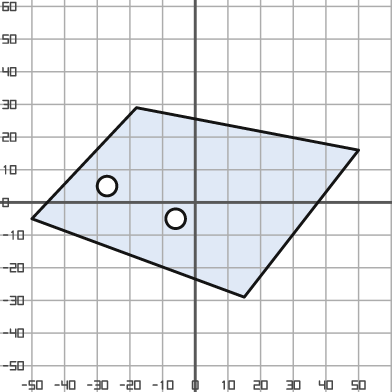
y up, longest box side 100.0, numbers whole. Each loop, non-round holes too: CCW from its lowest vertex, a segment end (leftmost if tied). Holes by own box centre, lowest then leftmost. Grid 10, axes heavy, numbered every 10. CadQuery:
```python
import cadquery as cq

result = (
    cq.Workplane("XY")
    .moveTo(15.0, -29.0)
    .lineTo(50.0, 16.0)
    .lineTo(-18.0, 29.0)
    .lineTo(-50.0, -5.0)
    .close()
    .moveTo(-6.0, -5.0)
    .circle(3.0)
    .moveTo(-27.0, 5.0)
    .circle(3.0)
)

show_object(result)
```